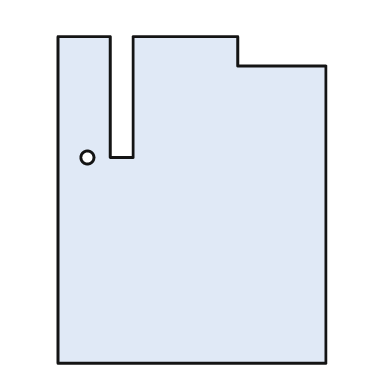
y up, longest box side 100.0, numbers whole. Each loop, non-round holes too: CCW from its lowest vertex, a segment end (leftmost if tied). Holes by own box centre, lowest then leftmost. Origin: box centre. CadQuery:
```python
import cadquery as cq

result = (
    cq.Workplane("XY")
    .moveTo(-41.0, -50.0)
    .lineTo(41.0, -50.0)
    .lineTo(41.0, 41.0)
    .lineTo(14.0, 41.0)
    .lineTo(14.0, 50.0)
    .lineTo(-18.0, 50.0)
    .lineTo(-18.0, 13.0)
    .lineTo(-25.0, 13.0)
    .lineTo(-25.0, 50.0)
    .lineTo(-41.0, 50.0)
    .close()
    .moveTo(-32.0, 13.0)
    .circle(2.0)
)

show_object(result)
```